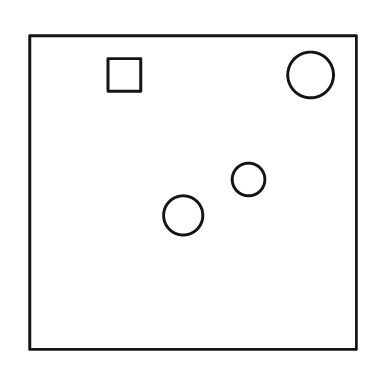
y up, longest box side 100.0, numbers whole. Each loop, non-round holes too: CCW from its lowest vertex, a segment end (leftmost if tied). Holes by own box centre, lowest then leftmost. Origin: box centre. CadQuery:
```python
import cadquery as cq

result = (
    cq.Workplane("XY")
    .moveTo(-50.0, -48.0)
    .lineTo(50.0, -48.0)
    .lineTo(50.0, 48.0)
    .lineTo(-50.0, 48.0)
    .close()
    .moveTo(-3.0, -7.0)
    .circle(6.0)
    .moveTo(17.0, 4.0)
    .circle(5.0)
    .moveTo(-26.0, 31.0)
    .lineTo(-16.0, 31.0)
    .lineTo(-16.0, 41.0)
    .lineTo(-26.0, 41.0)
    .close()
    .moveTo(36.0, 36.0)
    .circle(7.0)
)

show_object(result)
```